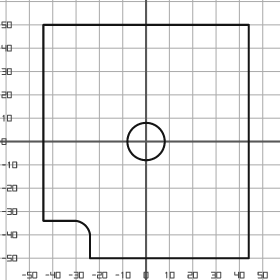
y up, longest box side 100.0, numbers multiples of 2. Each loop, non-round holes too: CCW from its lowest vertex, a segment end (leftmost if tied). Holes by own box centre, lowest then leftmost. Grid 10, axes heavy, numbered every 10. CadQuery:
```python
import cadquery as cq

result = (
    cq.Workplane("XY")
    .moveTo(-24.0, -50.0)
    .lineTo(44.0, -50.0)
    .lineTo(44.0, 50.0)
    .lineTo(-44.0, 50.0)
    .lineTo(-44.0, -34.0)
    .lineTo(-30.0, -34.0)
    .threePointArc((-26.0, -36.0), (-24.0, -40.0))
    .close()
    .moveTo(0.0, 0.0)
    .circle(8.0)
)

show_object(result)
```